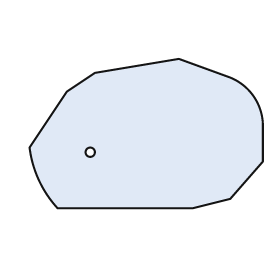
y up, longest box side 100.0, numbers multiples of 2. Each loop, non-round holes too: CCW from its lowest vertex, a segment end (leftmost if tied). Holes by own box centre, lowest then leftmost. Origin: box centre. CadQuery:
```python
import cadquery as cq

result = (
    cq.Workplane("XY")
    .moveTo(-38.0, -32.0)
    .lineTo(20.0, -32.0)
    .lineTo(36.0, -28.0)
    .lineTo(50.0, -12.0)
    .lineTo(50.0, 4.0)
    .threePointArc((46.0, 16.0), (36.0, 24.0))
    .lineTo(14.0, 32.0)
    .lineTo(-22.0, 26.0)
    .lineTo(-34.0, 18.0)
    .lineTo(-50.0, -6.0)
    .threePointArc((-46.0, -20.0), (-38.0, -32.0))
    .close()
    .moveTo(-24.0, -8.0)
    .circle(2.0)
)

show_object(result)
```